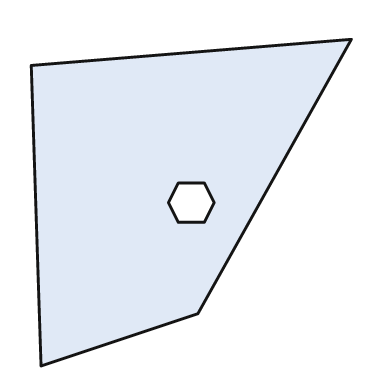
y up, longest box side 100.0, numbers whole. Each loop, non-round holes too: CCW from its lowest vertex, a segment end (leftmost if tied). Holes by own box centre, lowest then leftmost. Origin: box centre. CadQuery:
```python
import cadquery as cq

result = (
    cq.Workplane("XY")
    .moveTo(-46.0, -50.0)
    .lineTo(2.0, -34.0)
    .lineTo(49.0, 50.0)
    .lineTo(-49.0, 42.0)
    .close()
    .moveTo(-4.0, -6.0)
    .lineTo(4.0, -6.0)
    .lineTo(7.0, 0.0)
    .lineTo(4.0, 6.0)
    .lineTo(-4.0, 6.0)
    .lineTo(-7.0, 0.0)
    .close()
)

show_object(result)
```